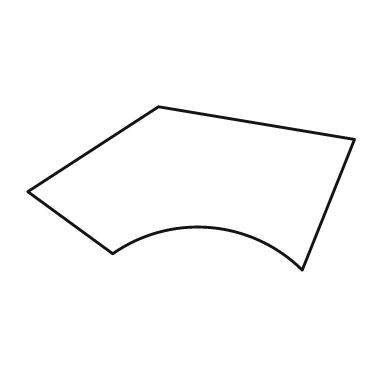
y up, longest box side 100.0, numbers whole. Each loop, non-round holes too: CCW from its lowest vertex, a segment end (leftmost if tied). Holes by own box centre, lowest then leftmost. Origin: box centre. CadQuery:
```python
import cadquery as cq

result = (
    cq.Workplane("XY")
    .moveTo(34.0, -25.0)
    .lineTo(50.0, 15.0)
    .lineTo(-10.0, 25.0)
    .lineTo(-50.0, -1.0)
    .lineTo(-24.0, -20.0)
    .threePointArc((6.0, -12.0), (34.0, -25.0))
    .close()
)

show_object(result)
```